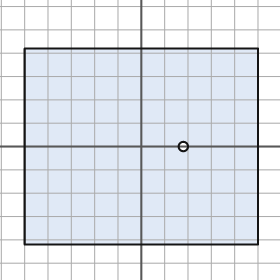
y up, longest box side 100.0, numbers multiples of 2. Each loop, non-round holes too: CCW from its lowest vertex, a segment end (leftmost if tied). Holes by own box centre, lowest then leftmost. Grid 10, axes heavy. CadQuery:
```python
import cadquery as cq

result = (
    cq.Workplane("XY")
    .moveTo(-50.0, -42.0)
    .lineTo(50.0, -42.0)
    .lineTo(50.0, 42.0)
    .lineTo(-50.0, 42.0)
    .close()
    .moveTo(18.0, 0.0)
    .circle(2.0)
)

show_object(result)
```